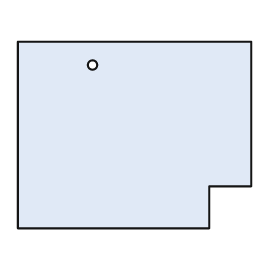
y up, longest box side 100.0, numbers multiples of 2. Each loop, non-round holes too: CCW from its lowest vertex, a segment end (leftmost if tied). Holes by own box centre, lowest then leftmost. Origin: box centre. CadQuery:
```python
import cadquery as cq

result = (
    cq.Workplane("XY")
    .moveTo(-50.0, -40.0)
    .lineTo(32.0, -40.0)
    .lineTo(32.0, -22.0)
    .lineTo(50.0, -22.0)
    .lineTo(50.0, 40.0)
    .lineTo(-50.0, 40.0)
    .close()
    .moveTo(-18.0, 30.0)
    .circle(2.0)
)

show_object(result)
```